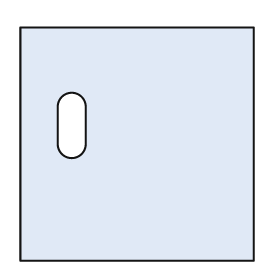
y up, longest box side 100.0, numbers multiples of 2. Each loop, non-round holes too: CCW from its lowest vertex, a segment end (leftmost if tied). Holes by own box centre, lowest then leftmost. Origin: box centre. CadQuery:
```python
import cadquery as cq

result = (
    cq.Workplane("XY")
    .moveTo(-50.0, -50.0)
    .lineTo(50.0, -50.0)
    .lineTo(50.0, 50.0)
    .lineTo(-50.0, 50.0)
    .close()
    .moveTo(-34.0, 0.0)
    .threePointArc((-28.0, -6.0), (-22.0, 0.0))
    .lineTo(-22.0, 16.0)
    .threePointArc((-28.0, 22.0), (-34.0, 16.0))
    .close()
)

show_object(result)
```